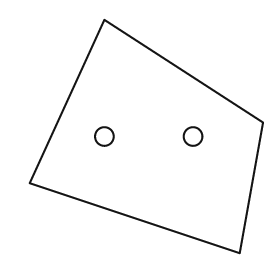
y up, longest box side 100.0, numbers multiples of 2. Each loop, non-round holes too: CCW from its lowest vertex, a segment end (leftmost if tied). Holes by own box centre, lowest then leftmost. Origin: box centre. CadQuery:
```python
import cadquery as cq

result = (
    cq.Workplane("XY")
    .moveTo(40.0, -50.0)
    .lineTo(50.0, 6.0)
    .lineTo(-18.0, 50.0)
    .lineTo(-50.0, -20.0)
    .close()
    .moveTo(-18.0, 0.0)
    .circle(4.0)
    .moveTo(20.0, 0.0)
    .circle(4.0)
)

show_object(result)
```